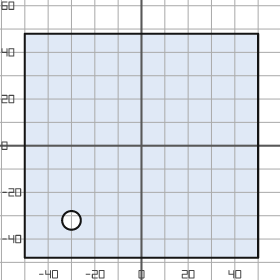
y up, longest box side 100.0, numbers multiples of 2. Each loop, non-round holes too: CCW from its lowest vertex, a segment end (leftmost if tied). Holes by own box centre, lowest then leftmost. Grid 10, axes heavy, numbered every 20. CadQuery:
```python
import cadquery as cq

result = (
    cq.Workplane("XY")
    .moveTo(-50.0, -48.0)
    .lineTo(50.0, -48.0)
    .lineTo(50.0, 48.0)
    .lineTo(-50.0, 48.0)
    .close()
    .moveTo(-30.0, -32.0)
    .circle(4.0)
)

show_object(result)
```